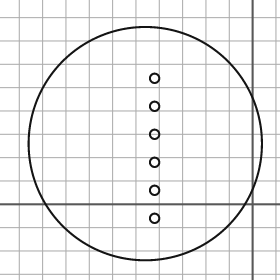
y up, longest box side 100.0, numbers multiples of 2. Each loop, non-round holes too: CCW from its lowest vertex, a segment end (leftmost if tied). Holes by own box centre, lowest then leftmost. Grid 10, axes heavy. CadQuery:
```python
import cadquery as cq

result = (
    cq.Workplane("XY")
    .moveTo(-46.0, 26.0)
    .circle(50.0)
    .moveTo(-42.0, -6.0)
    .circle(2.0)
    .moveTo(-42.0, 6.0)
    .circle(2.0)
    .moveTo(-42.0, 18.0)
    .circle(2.0)
    .moveTo(-42.0, 30.0)
    .circle(2.0)
    .moveTo(-42.0, 42.0)
    .circle(2.0)
    .moveTo(-42.0, 54.0)
    .circle(2.0)
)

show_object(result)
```